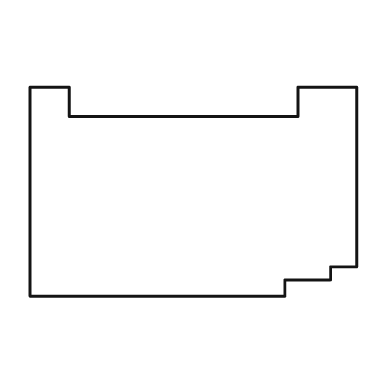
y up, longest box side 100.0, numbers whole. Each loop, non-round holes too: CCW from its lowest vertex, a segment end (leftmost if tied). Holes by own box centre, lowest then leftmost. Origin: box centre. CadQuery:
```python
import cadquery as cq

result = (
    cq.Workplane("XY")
    .moveTo(-50.0, -32.0)
    .lineTo(28.0, -32.0)
    .lineTo(28.0, -27.0)
    .lineTo(42.0, -27.0)
    .lineTo(42.0, -23.0)
    .lineTo(50.0, -23.0)
    .lineTo(50.0, 32.0)
    .lineTo(32.0, 32.0)
    .lineTo(32.0, 23.0)
    .lineTo(-38.0, 23.0)
    .lineTo(-38.0, 32.0)
    .lineTo(-50.0, 32.0)
    .close()
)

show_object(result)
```